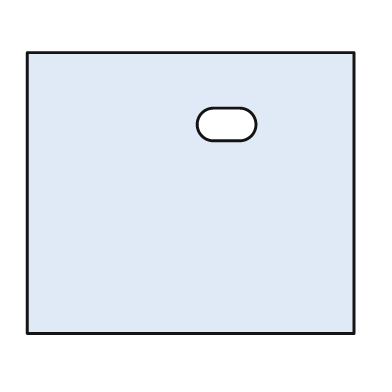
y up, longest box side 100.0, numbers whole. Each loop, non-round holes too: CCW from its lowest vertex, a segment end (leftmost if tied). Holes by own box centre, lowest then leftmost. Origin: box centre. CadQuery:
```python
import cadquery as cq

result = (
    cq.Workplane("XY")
    .moveTo(-50.0, -43.0)
    .lineTo(50.0, -43.0)
    .lineTo(50.0, 43.0)
    .lineTo(-50.0, 43.0)
    .close()
    .moveTo(7.0, 16.0)
    .lineTo(15.0, 16.0)
    .threePointArc((20.0, 21.0), (15.0, 26.0))
    .lineTo(7.0, 26.0)
    .threePointArc((2.0, 21.0), (7.0, 16.0))
    .close()
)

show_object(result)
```